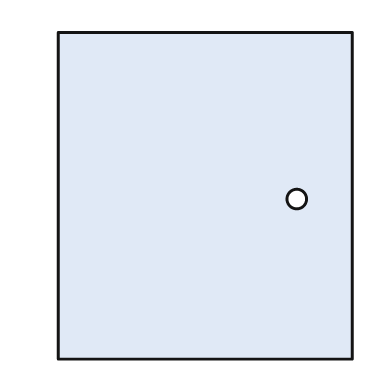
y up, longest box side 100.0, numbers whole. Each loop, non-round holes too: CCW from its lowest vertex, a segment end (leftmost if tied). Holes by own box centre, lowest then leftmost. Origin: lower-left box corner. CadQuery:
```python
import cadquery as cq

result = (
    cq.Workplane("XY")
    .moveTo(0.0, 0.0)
    .lineTo(90.0, 0.0)
    .lineTo(90.0, 100.0)
    .lineTo(0.0, 100.0)
    .close()
    .moveTo(73.0, 49.0)
    .circle(3.0)
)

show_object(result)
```